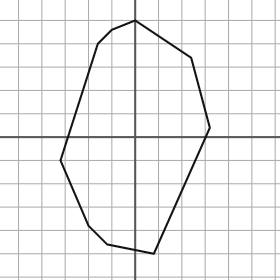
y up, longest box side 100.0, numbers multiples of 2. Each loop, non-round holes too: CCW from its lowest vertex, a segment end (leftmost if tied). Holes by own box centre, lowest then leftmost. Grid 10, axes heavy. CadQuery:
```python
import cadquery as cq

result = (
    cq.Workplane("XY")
    .moveTo(8.0, -50.0)
    .lineTo(32.0, 4.0)
    .lineTo(24.0, 34.0)
    .lineTo(0.0, 50.0)
    .lineTo(-10.0, 46.0)
    .lineTo(-16.0, 40.0)
    .lineTo(-32.0, -10.0)
    .lineTo(-20.0, -38.0)
    .lineTo(-12.0, -46.0)
    .close()
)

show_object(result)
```